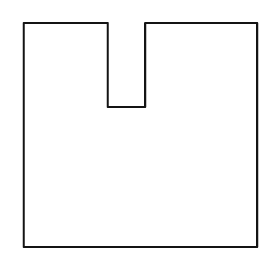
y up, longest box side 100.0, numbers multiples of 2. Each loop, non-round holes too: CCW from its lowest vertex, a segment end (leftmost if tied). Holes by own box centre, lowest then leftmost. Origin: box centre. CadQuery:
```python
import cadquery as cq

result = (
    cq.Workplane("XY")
    .moveTo(-50.0, -48.0)
    .lineTo(50.0, -48.0)
    .lineTo(50.0, 48.0)
    .lineTo(2.0, 48.0)
    .lineTo(2.0, 12.0)
    .lineTo(-14.0, 12.0)
    .lineTo(-14.0, 48.0)
    .lineTo(-50.0, 48.0)
    .close()
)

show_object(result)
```